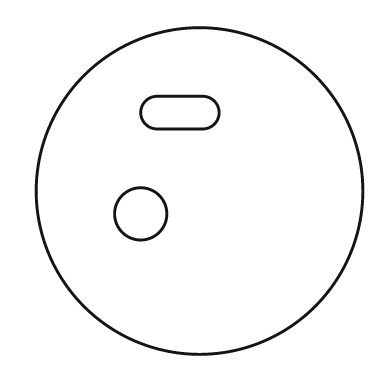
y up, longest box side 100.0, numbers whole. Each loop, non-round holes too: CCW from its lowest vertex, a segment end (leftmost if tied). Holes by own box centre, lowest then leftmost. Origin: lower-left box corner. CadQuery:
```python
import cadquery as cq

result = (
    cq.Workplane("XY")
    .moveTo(50.0, 50.0)
    .circle(50.0)
    .moveTo(32.0, 43.0)
    .circle(8.0)
    .moveTo(37.0, 69.0)
    .lineTo(51.0, 69.0)
    .threePointArc((56.0, 74.0), (51.0, 79.0))
    .lineTo(37.0, 79.0)
    .threePointArc((32.0, 74.0), (37.0, 69.0))
    .close()
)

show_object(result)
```